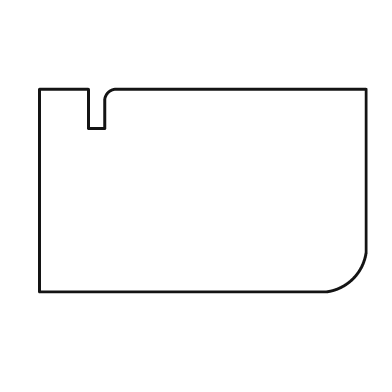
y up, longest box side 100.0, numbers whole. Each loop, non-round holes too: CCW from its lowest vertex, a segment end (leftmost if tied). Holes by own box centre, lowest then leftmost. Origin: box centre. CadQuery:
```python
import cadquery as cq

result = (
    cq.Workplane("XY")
    .moveTo(-50.0, -31.0)
    .lineTo(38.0, -31.0)
    .threePointArc((46.0, -27.0), (50.0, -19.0))
    .lineTo(50.0, 31.0)
    .lineTo(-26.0, 31.0)
    .threePointArc((-29.0, 30.0), (-30.0, 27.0))
    .lineTo(-30.0, 19.0)
    .lineTo(-35.0, 19.0)
    .lineTo(-35.0, 31.0)
    .lineTo(-50.0, 31.0)
    .close()
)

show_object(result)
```